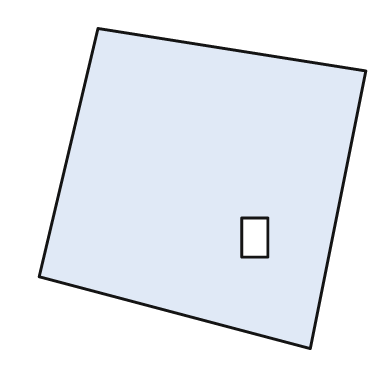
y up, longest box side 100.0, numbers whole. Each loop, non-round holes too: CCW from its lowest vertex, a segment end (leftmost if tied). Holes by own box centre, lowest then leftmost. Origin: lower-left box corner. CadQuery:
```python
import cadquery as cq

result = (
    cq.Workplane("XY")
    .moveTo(83.0, 0.0)
    .lineTo(100.0, 85.0)
    .lineTo(18.0, 98.0)
    .lineTo(0.0, 22.0)
    .close()
    .moveTo(62.0, 28.0)
    .lineTo(70.0, 28.0)
    .lineTo(70.0, 40.0)
    .lineTo(62.0, 40.0)
    .close()
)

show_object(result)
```